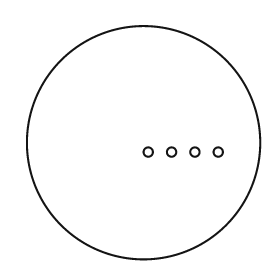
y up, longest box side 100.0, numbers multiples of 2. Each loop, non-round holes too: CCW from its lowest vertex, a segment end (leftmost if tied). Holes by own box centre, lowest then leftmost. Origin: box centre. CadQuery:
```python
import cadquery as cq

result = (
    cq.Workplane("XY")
    .moveTo(0.0, 0.0)
    .circle(50.0)
    .moveTo(2.0, -4.0)
    .circle(2.0)
    .moveTo(12.0, -4.0)
    .circle(2.0)
    .moveTo(22.0, -4.0)
    .circle(2.0)
    .moveTo(32.0, -4.0)
    .circle(2.0)
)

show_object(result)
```